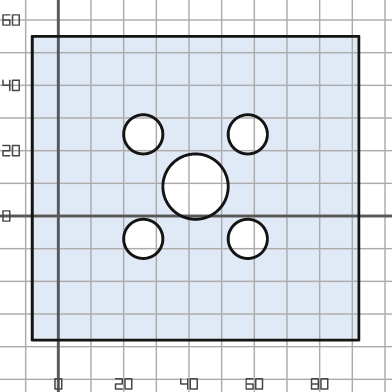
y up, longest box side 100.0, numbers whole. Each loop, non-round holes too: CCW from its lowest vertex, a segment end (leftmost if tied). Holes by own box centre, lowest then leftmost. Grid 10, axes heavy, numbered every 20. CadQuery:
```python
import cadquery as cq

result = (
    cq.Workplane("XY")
    .moveTo(-8.0, -38.0)
    .lineTo(92.0, -38.0)
    .lineTo(92.0, 55.0)
    .lineTo(-8.0, 55.0)
    .close()
    .moveTo(26.0, -7.0)
    .circle(6.0)
    .moveTo(58.0, -7.0)
    .circle(6.0)
    .moveTo(42.0, 9.0)
    .circle(10.0)
    .moveTo(26.0, 25.0)
    .circle(6.0)
    .moveTo(58.0, 25.0)
    .circle(6.0)
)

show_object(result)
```